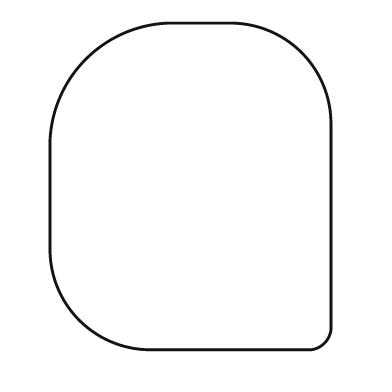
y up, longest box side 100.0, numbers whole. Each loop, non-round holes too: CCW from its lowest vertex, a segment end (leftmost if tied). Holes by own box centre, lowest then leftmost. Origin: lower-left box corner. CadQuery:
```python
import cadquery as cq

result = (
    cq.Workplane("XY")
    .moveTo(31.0, 0.0)
    .lineTo(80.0, 0.0)
    .threePointArc((84.0, 2.0), (86.0, 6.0))
    .lineTo(86.0, 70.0)
    .threePointArc((77.0, 91.0), (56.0, 100.0))
    .lineTo(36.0, 100.0)
    .threePointArc((11.0, 89.0), (0.0, 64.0))
    .lineTo(0.0, 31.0)
    .threePointArc((9.0, 9.0), (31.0, 0.0))
    .close()
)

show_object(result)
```